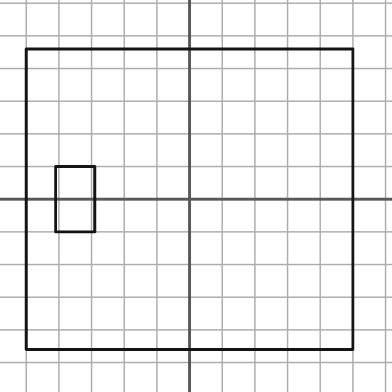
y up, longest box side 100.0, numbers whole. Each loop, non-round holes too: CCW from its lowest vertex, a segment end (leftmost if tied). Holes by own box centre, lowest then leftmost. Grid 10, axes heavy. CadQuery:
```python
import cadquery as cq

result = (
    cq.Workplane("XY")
    .moveTo(-50.0, -46.0)
    .lineTo(50.0, -46.0)
    .lineTo(50.0, 46.0)
    .lineTo(-50.0, 46.0)
    .close()
    .moveTo(-41.0, -10.0)
    .lineTo(-29.0, -10.0)
    .lineTo(-29.0, 10.0)
    .lineTo(-41.0, 10.0)
    .close()
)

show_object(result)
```